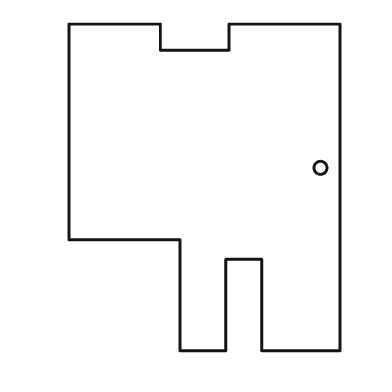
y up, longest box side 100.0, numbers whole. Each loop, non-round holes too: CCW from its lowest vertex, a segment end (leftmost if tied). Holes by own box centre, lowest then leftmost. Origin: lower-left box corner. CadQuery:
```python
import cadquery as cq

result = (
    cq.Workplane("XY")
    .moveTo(34.0, 0.0)
    .lineTo(48.0, 0.0)
    .lineTo(48.0, 28.0)
    .lineTo(59.0, 28.0)
    .lineTo(59.0, 0.0)
    .lineTo(83.0, 0.0)
    .lineTo(83.0, 100.0)
    .lineTo(49.0, 100.0)
    .lineTo(49.0, 92.0)
    .lineTo(28.0, 92.0)
    .lineTo(28.0, 100.0)
    .lineTo(0.0, 100.0)
    .lineTo(0.0, 34.0)
    .lineTo(34.0, 34.0)
    .close()
    .moveTo(77.0, 56.0)
    .circle(2.0)
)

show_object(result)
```